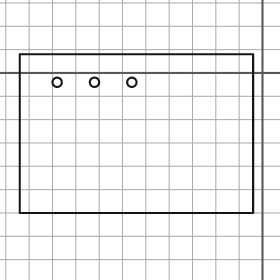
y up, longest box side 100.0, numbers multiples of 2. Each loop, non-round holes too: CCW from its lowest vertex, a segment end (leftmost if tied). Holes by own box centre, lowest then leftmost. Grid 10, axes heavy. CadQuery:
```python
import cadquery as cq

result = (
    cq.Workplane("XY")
    .moveTo(-104.0, -60.0)
    .lineTo(-4.0, -60.0)
    .lineTo(-4.0, 8.0)
    .lineTo(-104.0, 8.0)
    .close()
    .moveTo(-88.0, -4.0)
    .circle(2.0)
    .moveTo(-72.0, -4.0)
    .circle(2.0)
    .moveTo(-56.0, -4.0)
    .circle(2.0)
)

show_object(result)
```